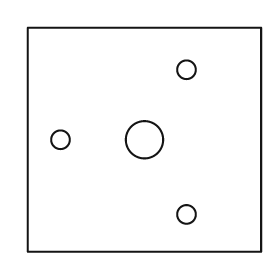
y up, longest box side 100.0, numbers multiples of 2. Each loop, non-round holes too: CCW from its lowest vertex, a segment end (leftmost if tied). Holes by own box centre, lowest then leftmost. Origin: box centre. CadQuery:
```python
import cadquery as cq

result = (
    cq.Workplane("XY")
    .moveTo(-50.0, -48.0)
    .lineTo(50.0, -48.0)
    .lineTo(50.0, 48.0)
    .lineTo(-50.0, 48.0)
    .close()
    .moveTo(18.0, -32.0)
    .circle(4.0)
    .moveTo(-36.0, 0.0)
    .circle(4.0)
    .moveTo(0.0, 0.0)
    .circle(8.0)
    .moveTo(18.0, 30.0)
    .circle(4.0)
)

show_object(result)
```